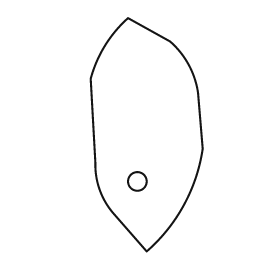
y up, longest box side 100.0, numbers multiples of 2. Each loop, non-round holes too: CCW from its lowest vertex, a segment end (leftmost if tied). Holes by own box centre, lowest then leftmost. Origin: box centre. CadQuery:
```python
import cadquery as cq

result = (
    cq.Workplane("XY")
    .moveTo(0.0, -50.0)
    .threePointArc((16.0, -30.0), (24.0, -6.0))
    .lineTo(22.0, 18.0)
    .threePointArc((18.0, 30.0), (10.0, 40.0))
    .lineTo(-8.0, 50.0)
    .threePointArc((-18.0, 38.0), (-24.0, 24.0))
    .lineTo(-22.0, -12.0)
    .threePointArc((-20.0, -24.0), (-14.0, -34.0))
    .close()
    .moveTo(-4.0, -20.0)
    .circle(4.0)
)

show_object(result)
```